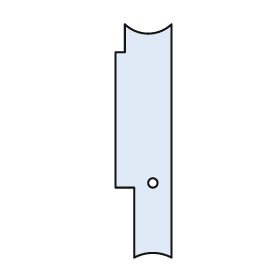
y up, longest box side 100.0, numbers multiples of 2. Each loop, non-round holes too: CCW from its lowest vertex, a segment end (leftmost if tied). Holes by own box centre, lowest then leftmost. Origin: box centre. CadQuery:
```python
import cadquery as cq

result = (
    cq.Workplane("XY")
    .moveTo(-4.0, -50.0)
    .threePointArc((4.0, -48.0), (12.0, -50.0))
    .lineTo(12.0, 50.0)
    .threePointArc((2.0, 46.0), (-8.0, 50.0))
    .lineTo(-8.0, 38.0)
    .lineTo(-12.0, 38.0)
    .lineTo(-12.0, -20.0)
    .lineTo(-4.0, -20.0)
    .close()
    .moveTo(4.0, -18.0)
    .circle(2.0)
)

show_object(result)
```